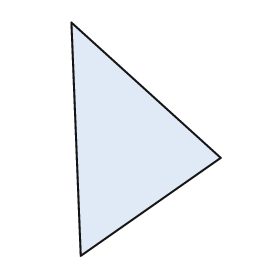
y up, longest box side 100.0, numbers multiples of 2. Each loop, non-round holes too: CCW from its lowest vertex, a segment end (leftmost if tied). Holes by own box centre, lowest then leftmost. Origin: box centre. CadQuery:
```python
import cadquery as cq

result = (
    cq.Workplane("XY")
    .moveTo(-28.0, -50.0)
    .lineTo(32.0, -8.0)
    .lineTo(-32.0, 50.0)
    .close()
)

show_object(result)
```